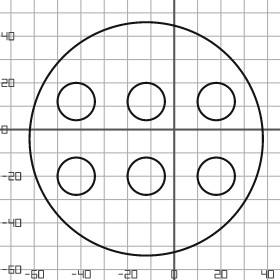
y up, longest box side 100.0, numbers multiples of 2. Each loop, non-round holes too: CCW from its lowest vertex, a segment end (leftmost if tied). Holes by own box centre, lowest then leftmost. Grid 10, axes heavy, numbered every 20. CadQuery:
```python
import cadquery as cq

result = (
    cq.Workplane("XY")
    .moveTo(-12.0, -4.0)
    .circle(50.0)
    .moveTo(-42.0, -20.0)
    .circle(8.0)
    .moveTo(-12.0, -20.0)
    .circle(8.0)
    .moveTo(18.0, -20.0)
    .circle(8.0)
    .moveTo(-42.0, 12.0)
    .circle(8.0)
    .moveTo(-12.0, 12.0)
    .circle(8.0)
    .moveTo(18.0, 12.0)
    .circle(8.0)
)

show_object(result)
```